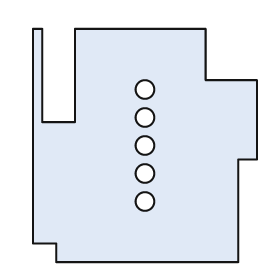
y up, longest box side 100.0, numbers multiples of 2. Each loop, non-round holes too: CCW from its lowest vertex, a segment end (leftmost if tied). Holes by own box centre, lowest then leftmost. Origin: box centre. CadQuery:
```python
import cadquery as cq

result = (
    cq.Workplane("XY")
    .moveTo(-38.0, -50.0)
    .lineTo(40.0, -50.0)
    .lineTo(40.0, -6.0)
    .lineTo(48.0, -6.0)
    .lineTo(48.0, 28.0)
    .lineTo(26.0, 28.0)
    .lineTo(26.0, 50.0)
    .lineTo(-30.0, 50.0)
    .lineTo(-30.0, 10.0)
    .lineTo(-44.0, 10.0)
    .lineTo(-44.0, 50.0)
    .lineTo(-48.0, 50.0)
    .lineTo(-48.0, -42.0)
    .lineTo(-38.0, -42.0)
    .close()
    .moveTo(0.0, -24.0)
    .circle(4.0)
    .moveTo(0.0, -12.0)
    .circle(4.0)
    .moveTo(0.0, 0.0)
    .circle(4.0)
    .moveTo(0.0, 12.0)
    .circle(4.0)
    .moveTo(0.0, 24.0)
    .circle(4.0)
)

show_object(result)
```